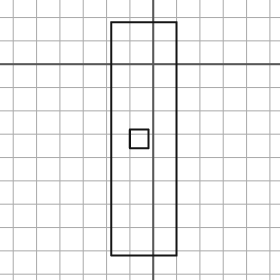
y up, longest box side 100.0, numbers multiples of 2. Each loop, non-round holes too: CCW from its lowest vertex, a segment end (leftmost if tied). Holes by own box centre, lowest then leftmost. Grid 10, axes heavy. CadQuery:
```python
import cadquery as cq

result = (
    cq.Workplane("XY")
    .moveTo(-18.0, -82.0)
    .lineTo(10.0, -82.0)
    .lineTo(10.0, 18.0)
    .lineTo(-18.0, 18.0)
    .close()
    .moveTo(-10.0, -36.0)
    .lineTo(-2.0, -36.0)
    .lineTo(-2.0, -28.0)
    .lineTo(-10.0, -28.0)
    .close()
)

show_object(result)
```